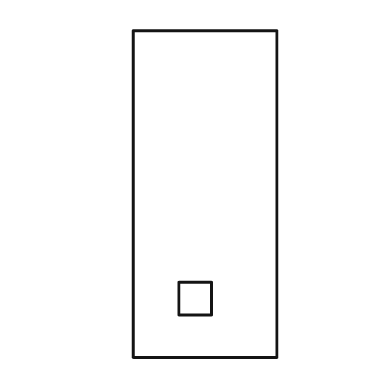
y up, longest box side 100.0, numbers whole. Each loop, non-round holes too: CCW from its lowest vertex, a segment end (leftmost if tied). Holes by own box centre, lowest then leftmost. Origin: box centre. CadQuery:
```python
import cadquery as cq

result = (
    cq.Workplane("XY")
    .moveTo(-22.0, -50.0)
    .lineTo(22.0, -50.0)
    .lineTo(22.0, 50.0)
    .lineTo(-22.0, 50.0)
    .close()
    .moveTo(-8.0, -37.0)
    .lineTo(2.0, -37.0)
    .lineTo(2.0, -27.0)
    .lineTo(-8.0, -27.0)
    .close()
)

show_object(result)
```